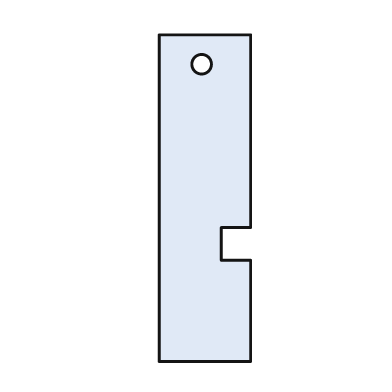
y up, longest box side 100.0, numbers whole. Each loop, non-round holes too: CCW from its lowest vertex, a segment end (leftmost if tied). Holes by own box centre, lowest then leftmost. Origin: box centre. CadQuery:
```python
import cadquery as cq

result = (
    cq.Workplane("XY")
    .moveTo(-14.0, -50.0)
    .lineTo(14.0, -50.0)
    .lineTo(14.0, -19.0)
    .lineTo(5.0, -19.0)
    .lineTo(5.0, -9.0)
    .lineTo(14.0, -9.0)
    .lineTo(14.0, 50.0)
    .lineTo(-14.0, 50.0)
    .close()
    .moveTo(-1.0, 41.0)
    .circle(3.0)
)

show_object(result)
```